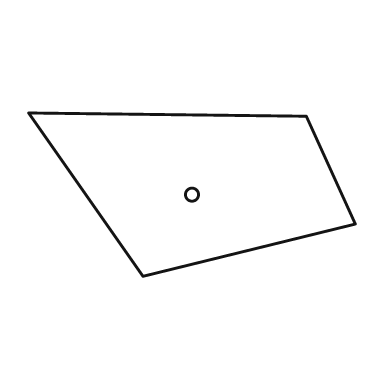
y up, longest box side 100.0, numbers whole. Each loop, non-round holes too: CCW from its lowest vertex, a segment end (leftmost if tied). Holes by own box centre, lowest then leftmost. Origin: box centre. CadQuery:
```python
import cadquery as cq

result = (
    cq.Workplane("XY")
    .moveTo(-15.0, -25.0)
    .lineTo(50.0, -9.0)
    .lineTo(35.0, 24.0)
    .lineTo(-50.0, 25.0)
    .close()
    .moveTo(0.0, 0.0)
    .circle(2.0)
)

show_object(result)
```